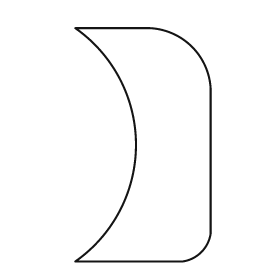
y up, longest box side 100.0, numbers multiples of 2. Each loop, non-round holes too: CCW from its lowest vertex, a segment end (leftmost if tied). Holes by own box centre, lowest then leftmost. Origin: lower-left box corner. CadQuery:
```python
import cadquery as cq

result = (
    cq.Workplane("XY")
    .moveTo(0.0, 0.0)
    .lineTo(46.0, 0.0)
    .threePointArc((54.0, 4.0), (58.0, 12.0))
    .lineTo(58.0, 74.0)
    .threePointArc((50.0, 92.0), (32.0, 100.0))
    .lineTo(0.0, 100.0)
    .threePointArc((26.0, 50.0), (0.0, 0.0))
    .close()
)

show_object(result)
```